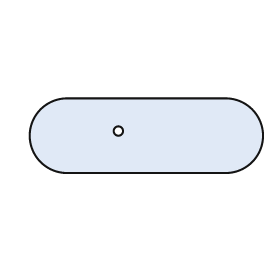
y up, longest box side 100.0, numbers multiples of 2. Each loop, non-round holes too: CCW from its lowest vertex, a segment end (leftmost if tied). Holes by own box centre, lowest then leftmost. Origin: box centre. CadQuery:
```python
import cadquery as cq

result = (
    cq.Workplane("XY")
    .moveTo(-34.0, -16.0)
    .lineTo(34.0, -16.0)
    .threePointArc((50.0, 0.0), (34.0, 16.0))
    .lineTo(-34.0, 16.0)
    .threePointArc((-50.0, 0.0), (-34.0, -16.0))
    .close()
    .moveTo(-12.0, 2.0)
    .circle(2.0)
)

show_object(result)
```